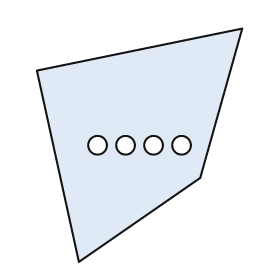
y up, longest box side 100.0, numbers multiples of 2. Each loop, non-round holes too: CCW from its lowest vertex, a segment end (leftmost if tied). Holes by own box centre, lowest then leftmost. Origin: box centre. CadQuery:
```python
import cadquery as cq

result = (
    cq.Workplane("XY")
    .moveTo(-26.0, -50.0)
    .lineTo(26.0, -14.0)
    .lineTo(44.0, 50.0)
    .lineTo(-44.0, 32.0)
    .close()
    .moveTo(-18.0, 0.0)
    .circle(4.0)
    .moveTo(-6.0, 0.0)
    .circle(4.0)
    .moveTo(6.0, 0.0)
    .circle(4.0)
    .moveTo(18.0, 0.0)
    .circle(4.0)
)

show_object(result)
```